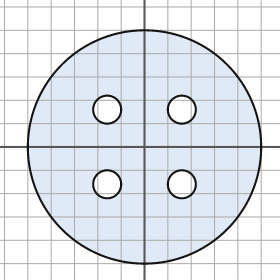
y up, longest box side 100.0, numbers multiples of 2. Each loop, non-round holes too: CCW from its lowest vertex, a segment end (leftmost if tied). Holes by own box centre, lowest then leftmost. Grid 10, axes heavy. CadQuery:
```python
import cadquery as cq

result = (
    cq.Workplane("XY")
    .moveTo(0.0, 0.0)
    .circle(50.0)
    .moveTo(-16.0, -16.0)
    .circle(6.0)
    .moveTo(16.0, -16.0)
    .circle(6.0)
    .moveTo(-16.0, 16.0)
    .circle(6.0)
    .moveTo(16.0, 16.0)
    .circle(6.0)
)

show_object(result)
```